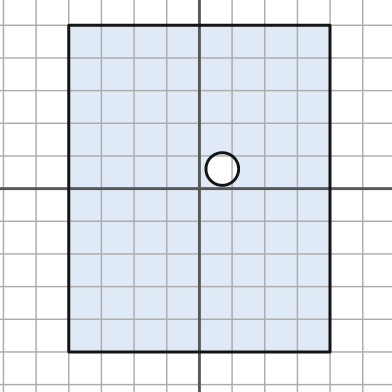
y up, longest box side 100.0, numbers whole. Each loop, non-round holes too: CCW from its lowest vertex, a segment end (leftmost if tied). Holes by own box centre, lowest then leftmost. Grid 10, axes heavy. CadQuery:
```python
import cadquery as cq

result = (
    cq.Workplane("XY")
    .moveTo(-40.0, -50.0)
    .lineTo(40.0, -50.0)
    .lineTo(40.0, 50.0)
    .lineTo(-40.0, 50.0)
    .close()
    .moveTo(7.0, 6.0)
    .circle(5.0)
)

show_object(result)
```